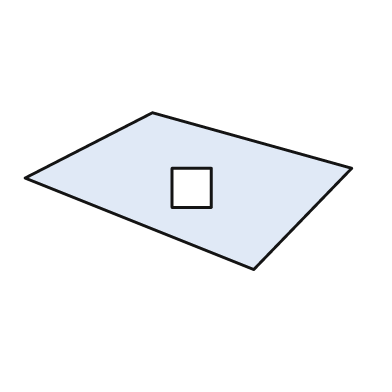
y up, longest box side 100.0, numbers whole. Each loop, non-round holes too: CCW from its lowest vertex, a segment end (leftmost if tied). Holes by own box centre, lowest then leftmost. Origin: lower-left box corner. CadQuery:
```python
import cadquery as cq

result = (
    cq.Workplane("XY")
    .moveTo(70.0, 0.0)
    .lineTo(100.0, 31.0)
    .lineTo(39.0, 48.0)
    .lineTo(0.0, 28.0)
    .close()
    .moveTo(45.0, 19.0)
    .lineTo(57.0, 19.0)
    .lineTo(57.0, 31.0)
    .lineTo(45.0, 31.0)
    .close()
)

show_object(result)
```